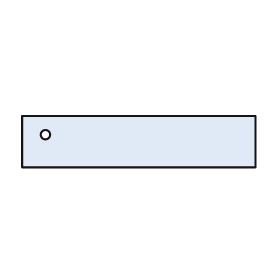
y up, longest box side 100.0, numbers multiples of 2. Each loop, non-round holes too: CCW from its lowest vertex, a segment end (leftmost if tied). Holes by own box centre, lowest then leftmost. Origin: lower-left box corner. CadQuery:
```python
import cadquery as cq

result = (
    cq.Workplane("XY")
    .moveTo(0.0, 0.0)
    .lineTo(100.0, 0.0)
    .lineTo(100.0, 22.0)
    .lineTo(0.0, 22.0)
    .close()
    .moveTo(10.0, 14.0)
    .circle(2.0)
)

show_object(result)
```